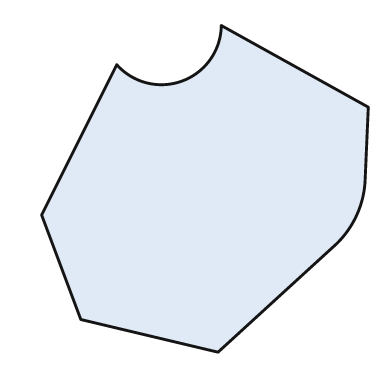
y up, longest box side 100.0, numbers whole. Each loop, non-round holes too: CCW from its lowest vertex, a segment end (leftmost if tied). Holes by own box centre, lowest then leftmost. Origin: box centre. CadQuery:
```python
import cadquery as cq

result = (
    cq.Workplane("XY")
    .moveTo(4.0, -50.0)
    .lineTo(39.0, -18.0)
    .threePointArc((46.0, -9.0), (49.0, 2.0))
    .lineTo(50.0, 25.0)
    .lineTo(5.0, 50.0)
    .threePointArc((-7.0, 33.0), (-27.0, 38.0))
    .lineTo(-50.0, -8.0)
    .lineTo(-38.0, -40.0)
    .close()
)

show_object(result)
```